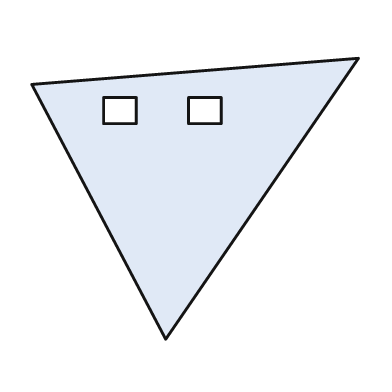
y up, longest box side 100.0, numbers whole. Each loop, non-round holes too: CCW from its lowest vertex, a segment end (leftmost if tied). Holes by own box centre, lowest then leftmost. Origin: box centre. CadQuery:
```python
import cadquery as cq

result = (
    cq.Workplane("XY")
    .moveTo(-9.0, -43.0)
    .lineTo(50.0, 43.0)
    .lineTo(-50.0, 35.0)
    .close()
    .moveTo(-28.0, 23.0)
    .lineTo(-18.0, 23.0)
    .lineTo(-18.0, 31.0)
    .lineTo(-28.0, 31.0)
    .close()
    .moveTo(-2.0, 23.0)
    .lineTo(8.0, 23.0)
    .lineTo(8.0, 31.0)
    .lineTo(-2.0, 31.0)
    .close()
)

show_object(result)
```